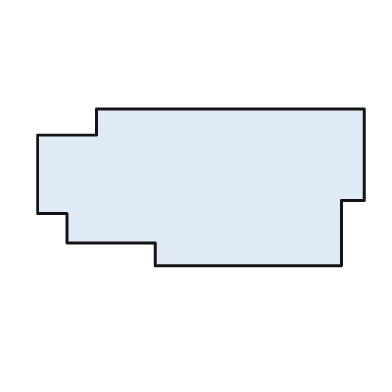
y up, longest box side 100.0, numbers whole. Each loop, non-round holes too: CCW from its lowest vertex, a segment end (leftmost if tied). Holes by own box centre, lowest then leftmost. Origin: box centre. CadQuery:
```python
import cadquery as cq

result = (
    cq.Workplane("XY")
    .moveTo(-14.0, -24.0)
    .lineTo(43.0, -24.0)
    .lineTo(43.0, -4.0)
    .lineTo(50.0, -4.0)
    .lineTo(50.0, 24.0)
    .lineTo(-32.0, 24.0)
    .lineTo(-32.0, 16.0)
    .lineTo(-50.0, 16.0)
    .lineTo(-50.0, -8.0)
    .lineTo(-41.0, -8.0)
    .lineTo(-41.0, -17.0)
    .lineTo(-14.0, -17.0)
    .close()
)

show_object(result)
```